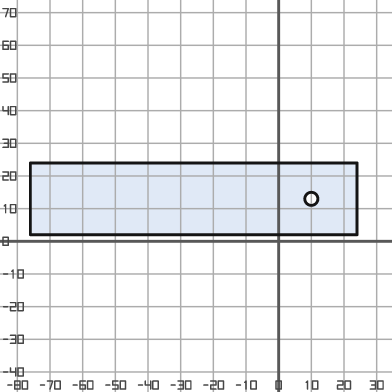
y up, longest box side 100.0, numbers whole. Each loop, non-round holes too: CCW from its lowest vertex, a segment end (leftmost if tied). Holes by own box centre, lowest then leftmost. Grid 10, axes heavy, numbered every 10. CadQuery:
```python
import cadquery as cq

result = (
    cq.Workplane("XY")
    .moveTo(-76.0, 2.0)
    .lineTo(24.0, 2.0)
    .lineTo(24.0, 24.0)
    .lineTo(-76.0, 24.0)
    .close()
    .moveTo(10.0, 13.0)
    .circle(2.0)
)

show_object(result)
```